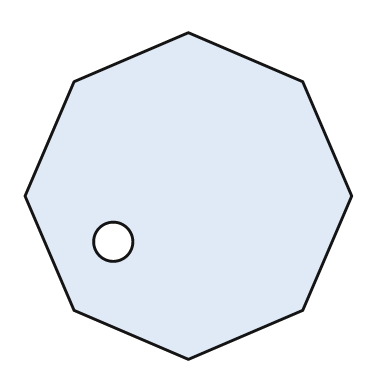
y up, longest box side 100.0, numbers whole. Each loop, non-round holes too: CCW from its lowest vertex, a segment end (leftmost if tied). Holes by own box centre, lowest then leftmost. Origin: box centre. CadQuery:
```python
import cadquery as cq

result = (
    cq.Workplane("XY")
    .moveTo(0.0, -50.0)
    .lineTo(35.0, -35.0)
    .lineTo(50.0, 0.0)
    .lineTo(35.0, 35.0)
    .lineTo(0.0, 50.0)
    .lineTo(-35.0, 35.0)
    .lineTo(-50.0, 0.0)
    .lineTo(-35.0, -35.0)
    .close()
    .moveTo(-23.0, -14.0)
    .circle(6.0)
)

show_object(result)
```